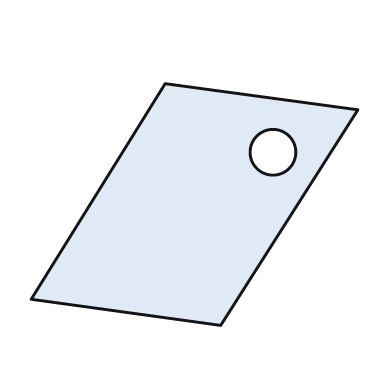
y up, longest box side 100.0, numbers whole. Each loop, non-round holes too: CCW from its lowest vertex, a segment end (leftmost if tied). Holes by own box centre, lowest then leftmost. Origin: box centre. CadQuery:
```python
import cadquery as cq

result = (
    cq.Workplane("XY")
    .moveTo(8.0, -37.0)
    .lineTo(50.0, 29.0)
    .lineTo(-9.0, 37.0)
    .lineTo(-50.0, -29.0)
    .close()
    .moveTo(24.0, 16.0)
    .circle(7.0)
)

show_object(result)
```